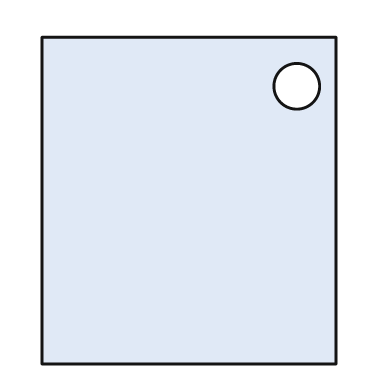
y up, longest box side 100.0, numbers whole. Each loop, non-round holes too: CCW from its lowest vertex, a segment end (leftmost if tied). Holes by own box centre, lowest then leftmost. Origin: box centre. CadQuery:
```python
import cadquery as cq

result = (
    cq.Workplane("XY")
    .moveTo(-45.0, -50.0)
    .lineTo(45.0, -50.0)
    .lineTo(45.0, 50.0)
    .lineTo(-45.0, 50.0)
    .close()
    .moveTo(33.0, 35.0)
    .circle(7.0)
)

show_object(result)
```